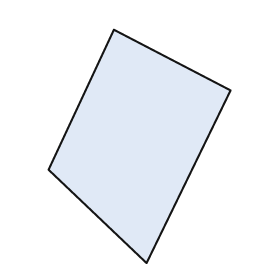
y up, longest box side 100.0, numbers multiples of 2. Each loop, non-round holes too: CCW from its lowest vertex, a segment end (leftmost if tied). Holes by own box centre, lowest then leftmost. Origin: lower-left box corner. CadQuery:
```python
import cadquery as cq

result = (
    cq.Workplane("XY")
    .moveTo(42.0, 0.0)
    .lineTo(78.0, 74.0)
    .lineTo(28.0, 100.0)
    .lineTo(0.0, 40.0)
    .close()
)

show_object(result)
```